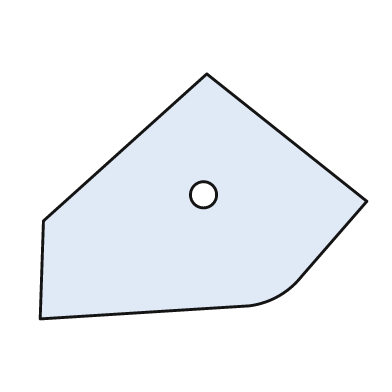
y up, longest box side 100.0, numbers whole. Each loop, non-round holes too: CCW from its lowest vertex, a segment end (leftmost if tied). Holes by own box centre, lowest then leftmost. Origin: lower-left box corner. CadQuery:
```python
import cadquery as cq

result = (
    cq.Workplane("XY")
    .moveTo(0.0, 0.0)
    .lineTo(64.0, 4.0)
    .threePointArc((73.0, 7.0), (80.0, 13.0))
    .lineTo(100.0, 36.0)
    .lineTo(51.0, 75.0)
    .lineTo(1.0, 30.0)
    .close()
    .moveTo(50.0, 38.0)
    .circle(4.0)
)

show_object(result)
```